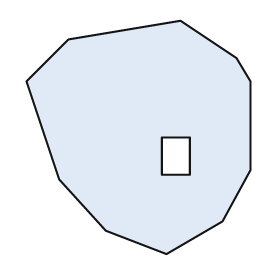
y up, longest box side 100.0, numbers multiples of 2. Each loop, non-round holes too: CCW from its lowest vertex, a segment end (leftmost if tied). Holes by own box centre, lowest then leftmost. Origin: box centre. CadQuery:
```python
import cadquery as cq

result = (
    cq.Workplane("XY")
    .moveTo(12.0, -50.0)
    .lineTo(36.0, -36.0)
    .lineTo(48.0, -14.0)
    .lineTo(48.0, 24.0)
    .lineTo(42.0, 34.0)
    .lineTo(18.0, 50.0)
    .lineTo(-30.0, 42.0)
    .lineTo(-48.0, 24.0)
    .lineTo(-34.0, -18.0)
    .lineTo(-14.0, -40.0)
    .close()
    .moveTo(10.0, -16.0)
    .lineTo(22.0, -16.0)
    .lineTo(22.0, 0.0)
    .lineTo(10.0, 0.0)
    .close()
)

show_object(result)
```